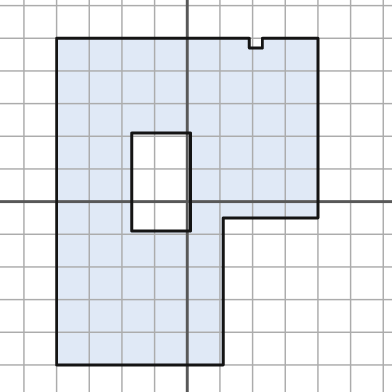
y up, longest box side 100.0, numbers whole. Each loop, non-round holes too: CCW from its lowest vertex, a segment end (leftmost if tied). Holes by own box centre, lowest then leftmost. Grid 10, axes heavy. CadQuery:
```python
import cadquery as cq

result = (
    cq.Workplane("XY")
    .moveTo(-40.0, -50.0)
    .lineTo(11.0, -50.0)
    .lineTo(11.0, -5.0)
    .lineTo(40.0, -5.0)
    .lineTo(40.0, 50.0)
    .lineTo(23.0, 50.0)
    .lineTo(23.0, 47.0)
    .lineTo(19.0, 47.0)
    .lineTo(19.0, 50.0)
    .lineTo(-40.0, 50.0)
    .close()
    .moveTo(-17.0, -9.0)
    .lineTo(1.0, -9.0)
    .lineTo(1.0, 21.0)
    .lineTo(-17.0, 21.0)
    .close()
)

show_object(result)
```